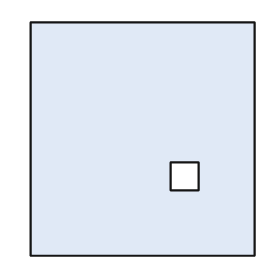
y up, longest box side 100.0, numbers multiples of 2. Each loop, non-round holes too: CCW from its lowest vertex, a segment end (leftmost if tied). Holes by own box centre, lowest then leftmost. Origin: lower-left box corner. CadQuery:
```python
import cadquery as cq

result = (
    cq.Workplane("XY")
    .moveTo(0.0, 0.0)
    .lineTo(96.0, 0.0)
    .lineTo(96.0, 100.0)
    .lineTo(0.0, 100.0)
    .close()
    .moveTo(60.0, 28.0)
    .lineTo(72.0, 28.0)
    .lineTo(72.0, 40.0)
    .lineTo(60.0, 40.0)
    .close()
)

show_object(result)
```